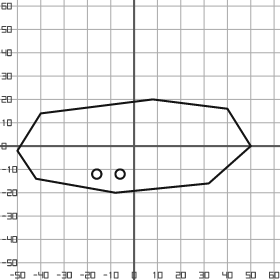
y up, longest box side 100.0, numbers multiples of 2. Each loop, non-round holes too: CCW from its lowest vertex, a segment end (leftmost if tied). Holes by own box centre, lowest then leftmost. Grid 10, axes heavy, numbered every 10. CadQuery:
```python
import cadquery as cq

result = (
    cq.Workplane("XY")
    .moveTo(-8.0, -20.0)
    .lineTo(32.0, -16.0)
    .lineTo(50.0, 0.0)
    .lineTo(40.0, 16.0)
    .lineTo(8.0, 20.0)
    .lineTo(-40.0, 14.0)
    .lineTo(-50.0, -2.0)
    .lineTo(-42.0, -14.0)
    .close()
    .moveTo(-16.0, -12.0)
    .circle(2.0)
    .moveTo(-6.0, -12.0)
    .circle(2.0)
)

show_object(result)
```